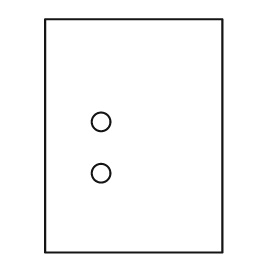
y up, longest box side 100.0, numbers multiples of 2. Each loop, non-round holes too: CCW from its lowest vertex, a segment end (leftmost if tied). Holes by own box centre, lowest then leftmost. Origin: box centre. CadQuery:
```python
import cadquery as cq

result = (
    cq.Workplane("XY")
    .moveTo(-38.0, -50.0)
    .lineTo(38.0, -50.0)
    .lineTo(38.0, 50.0)
    .lineTo(-38.0, 50.0)
    .close()
    .moveTo(-14.0, -16.0)
    .circle(4.0)
    .moveTo(-14.0, 6.0)
    .circle(4.0)
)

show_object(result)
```